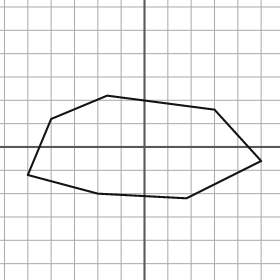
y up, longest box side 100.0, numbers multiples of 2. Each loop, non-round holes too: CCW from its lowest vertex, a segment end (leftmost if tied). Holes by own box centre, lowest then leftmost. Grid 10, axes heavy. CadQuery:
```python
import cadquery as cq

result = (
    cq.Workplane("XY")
    .moveTo(18.0, -22.0)
    .lineTo(50.0, -6.0)
    .lineTo(30.0, 16.0)
    .lineTo(-16.0, 22.0)
    .lineTo(-40.0, 12.0)
    .lineTo(-50.0, -12.0)
    .lineTo(-20.0, -20.0)
    .close()
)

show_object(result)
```